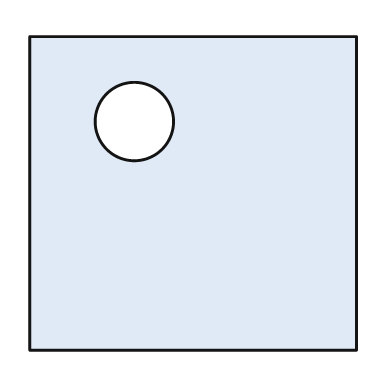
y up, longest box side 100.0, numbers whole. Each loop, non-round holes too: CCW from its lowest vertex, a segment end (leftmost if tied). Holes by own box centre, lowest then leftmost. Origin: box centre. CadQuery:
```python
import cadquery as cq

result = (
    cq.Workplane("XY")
    .moveTo(-50.0, -48.0)
    .lineTo(50.0, -48.0)
    .lineTo(50.0, 48.0)
    .lineTo(-50.0, 48.0)
    .close()
    .moveTo(-18.0, 22.0)
    .circle(12.0)
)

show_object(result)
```